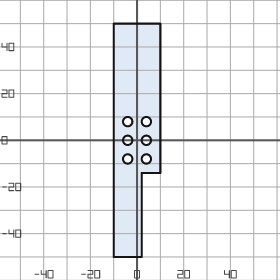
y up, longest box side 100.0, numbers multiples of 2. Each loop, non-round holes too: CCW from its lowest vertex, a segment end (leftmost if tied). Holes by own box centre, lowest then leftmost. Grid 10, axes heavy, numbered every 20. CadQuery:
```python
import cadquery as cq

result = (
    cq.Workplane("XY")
    .moveTo(-10.0, -50.0)
    .lineTo(2.0, -50.0)
    .lineTo(2.0, -14.0)
    .lineTo(10.0, -14.0)
    .lineTo(10.0, 50.0)
    .lineTo(-10.0, 50.0)
    .close()
    .moveTo(-4.0, -8.0)
    .circle(2.0)
    .moveTo(4.0, -8.0)
    .circle(2.0)
    .moveTo(-4.0, 0.0)
    .circle(2.0)
    .moveTo(4.0, 0.0)
    .circle(2.0)
    .moveTo(-4.0, 8.0)
    .circle(2.0)
    .moveTo(4.0, 8.0)
    .circle(2.0)
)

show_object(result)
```